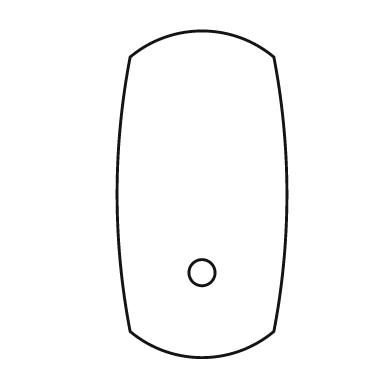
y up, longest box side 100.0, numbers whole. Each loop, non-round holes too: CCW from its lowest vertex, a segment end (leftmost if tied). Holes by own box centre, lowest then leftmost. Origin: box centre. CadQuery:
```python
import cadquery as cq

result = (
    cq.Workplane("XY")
    .moveTo(-22.0, -42.0)
    .threePointArc((0.0, -50.0), (22.0, -42.0))
    .threePointArc((26.0, 0.0), (22.0, 42.0))
    .threePointArc((0.0, 50.0), (-22.0, 42.0))
    .threePointArc((-26.0, 0.0), (-22.0, -42.0))
    .close()
    .moveTo(0.0, -24.0)
    .circle(4.0)
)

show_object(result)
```